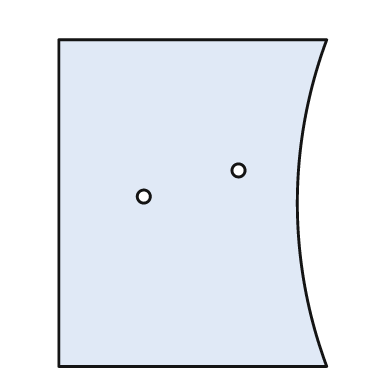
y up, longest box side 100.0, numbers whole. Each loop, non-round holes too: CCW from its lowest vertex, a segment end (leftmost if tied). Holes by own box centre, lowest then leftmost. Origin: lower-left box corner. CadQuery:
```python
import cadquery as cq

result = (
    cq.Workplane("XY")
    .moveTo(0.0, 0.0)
    .lineTo(82.0, 0.0)
    .threePointArc((73.0, 50.0), (82.0, 100.0))
    .lineTo(0.0, 100.0)
    .close()
    .moveTo(26.0, 52.0)
    .circle(2.0)
    .moveTo(55.0, 60.0)
    .circle(2.0)
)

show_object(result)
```